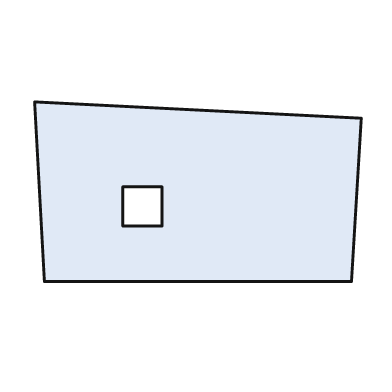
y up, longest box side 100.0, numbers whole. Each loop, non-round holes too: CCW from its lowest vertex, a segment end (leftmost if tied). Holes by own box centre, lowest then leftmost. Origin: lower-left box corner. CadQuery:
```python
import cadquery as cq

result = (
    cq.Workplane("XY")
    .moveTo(3.0, 0.0)
    .lineTo(97.0, 0.0)
    .lineTo(100.0, 50.0)
    .lineTo(0.0, 55.0)
    .close()
    .moveTo(27.0, 17.0)
    .lineTo(39.0, 17.0)
    .lineTo(39.0, 29.0)
    .lineTo(27.0, 29.0)
    .close()
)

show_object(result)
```